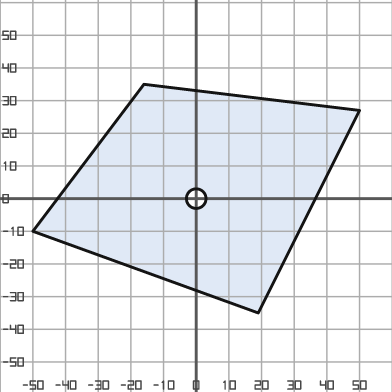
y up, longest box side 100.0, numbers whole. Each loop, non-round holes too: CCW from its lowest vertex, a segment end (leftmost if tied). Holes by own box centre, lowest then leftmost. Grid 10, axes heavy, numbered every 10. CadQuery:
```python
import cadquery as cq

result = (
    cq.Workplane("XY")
    .moveTo(19.0, -35.0)
    .lineTo(50.0, 27.0)
    .lineTo(-16.0, 35.0)
    .lineTo(-50.0, -10.0)
    .close()
    .moveTo(0.0, 0.0)
    .circle(3.0)
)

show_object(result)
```